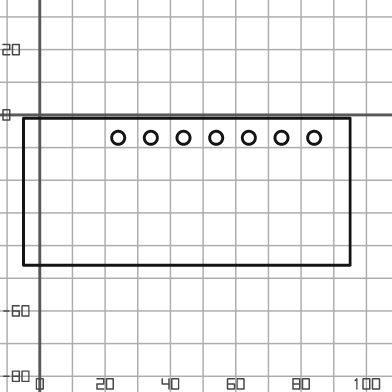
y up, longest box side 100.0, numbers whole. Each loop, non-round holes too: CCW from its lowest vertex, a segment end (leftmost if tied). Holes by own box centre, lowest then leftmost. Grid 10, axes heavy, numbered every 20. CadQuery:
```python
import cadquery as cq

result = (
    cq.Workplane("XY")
    .moveTo(-5.0, -46.0)
    .lineTo(95.0, -46.0)
    .lineTo(95.0, -1.0)
    .lineTo(-5.0, -1.0)
    .close()
    .moveTo(24.0, -7.0)
    .circle(2.0)
    .moveTo(34.0, -7.0)
    .circle(2.0)
    .moveTo(44.0, -7.0)
    .circle(2.0)
    .moveTo(54.0, -7.0)
    .circle(2.0)
    .moveTo(64.0, -7.0)
    .circle(2.0)
    .moveTo(74.0, -7.0)
    .circle(2.0)
    .moveTo(84.0, -7.0)
    .circle(2.0)
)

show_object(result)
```